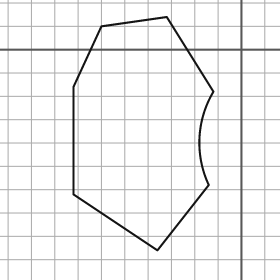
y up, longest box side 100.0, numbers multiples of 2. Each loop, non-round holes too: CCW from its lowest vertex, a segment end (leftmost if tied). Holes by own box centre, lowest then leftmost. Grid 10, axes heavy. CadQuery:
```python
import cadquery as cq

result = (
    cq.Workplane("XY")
    .moveTo(-36.0, -86.0)
    .lineTo(-14.0, -58.0)
    .threePointArc((-18.0, -38.0), (-12.0, -18.0))
    .lineTo(-32.0, 14.0)
    .lineTo(-60.0, 10.0)
    .lineTo(-72.0, -16.0)
    .lineTo(-72.0, -62.0)
    .close()
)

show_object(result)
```